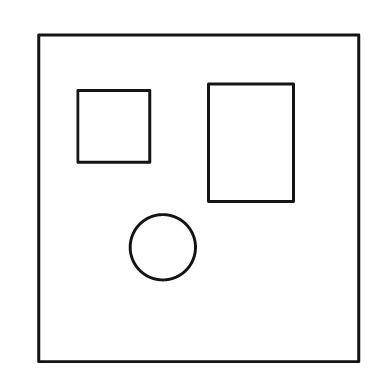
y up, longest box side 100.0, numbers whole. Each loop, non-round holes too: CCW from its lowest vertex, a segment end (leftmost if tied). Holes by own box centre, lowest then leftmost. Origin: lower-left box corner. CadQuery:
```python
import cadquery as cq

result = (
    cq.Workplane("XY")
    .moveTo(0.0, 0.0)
    .lineTo(98.0, 0.0)
    .lineTo(98.0, 100.0)
    .lineTo(0.0, 100.0)
    .close()
    .moveTo(38.0, 35.0)
    .circle(10.0)
    .moveTo(52.0, 49.0)
    .lineTo(78.0, 49.0)
    .lineTo(78.0, 85.0)
    .lineTo(52.0, 85.0)
    .close()
    .moveTo(12.0, 61.0)
    .lineTo(34.0, 61.0)
    .lineTo(34.0, 83.0)
    .lineTo(12.0, 83.0)
    .close()
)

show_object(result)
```